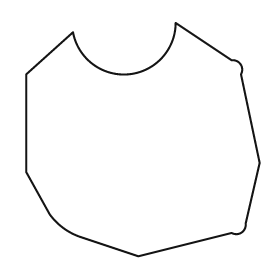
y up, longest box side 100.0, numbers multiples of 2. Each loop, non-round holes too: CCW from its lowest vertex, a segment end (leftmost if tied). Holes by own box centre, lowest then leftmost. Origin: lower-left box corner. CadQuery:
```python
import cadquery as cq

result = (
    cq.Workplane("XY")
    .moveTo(48.0, 0.0)
    .lineTo(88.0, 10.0)
    .threePointArc((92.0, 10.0), (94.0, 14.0))
    .lineTo(100.0, 40.0)
    .lineTo(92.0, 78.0)
    .threePointArc((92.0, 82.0), (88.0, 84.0))
    .lineTo(64.0, 100.0)
    .threePointArc((44.0, 78.0), (20.0, 96.0))
    .lineTo(0.0, 78.0)
    .lineTo(0.0, 36.0)
    .lineTo(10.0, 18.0)
    .threePointArc((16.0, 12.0), (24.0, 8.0))
    .close()
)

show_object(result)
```